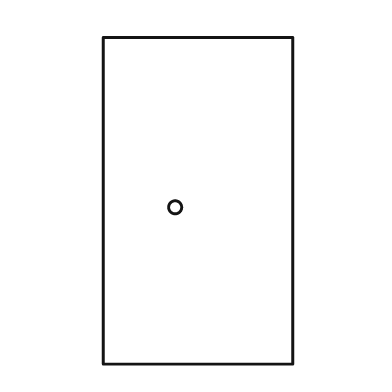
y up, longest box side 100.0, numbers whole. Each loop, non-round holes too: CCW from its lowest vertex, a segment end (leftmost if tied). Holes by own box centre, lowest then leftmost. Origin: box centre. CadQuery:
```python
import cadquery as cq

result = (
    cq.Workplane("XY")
    .moveTo(-29.0, -50.0)
    .lineTo(29.0, -50.0)
    .lineTo(29.0, 50.0)
    .lineTo(-29.0, 50.0)
    .close()
    .moveTo(-7.0, -2.0)
    .circle(2.0)
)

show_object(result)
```